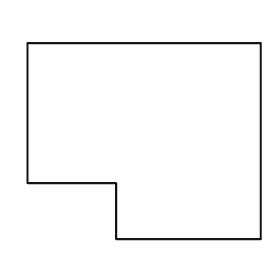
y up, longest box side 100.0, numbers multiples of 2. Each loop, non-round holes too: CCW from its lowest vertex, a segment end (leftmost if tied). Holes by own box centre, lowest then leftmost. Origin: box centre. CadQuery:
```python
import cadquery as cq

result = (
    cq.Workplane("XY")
    .moveTo(-12.0, -42.0)
    .lineTo(50.0, -42.0)
    .lineTo(50.0, 42.0)
    .lineTo(-50.0, 42.0)
    .lineTo(-50.0, -18.0)
    .lineTo(-12.0, -18.0)
    .close()
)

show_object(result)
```